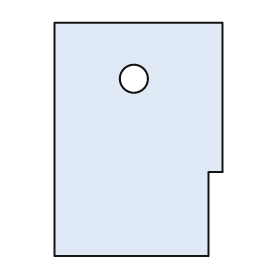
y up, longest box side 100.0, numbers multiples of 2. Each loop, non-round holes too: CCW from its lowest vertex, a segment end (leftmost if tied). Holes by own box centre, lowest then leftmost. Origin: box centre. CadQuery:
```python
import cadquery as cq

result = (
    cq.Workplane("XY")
    .moveTo(-36.0, -50.0)
    .lineTo(30.0, -50.0)
    .lineTo(30.0, -14.0)
    .lineTo(36.0, -14.0)
    .lineTo(36.0, 50.0)
    .lineTo(-36.0, 50.0)
    .close()
    .moveTo(-2.0, 26.0)
    .circle(6.0)
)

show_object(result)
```